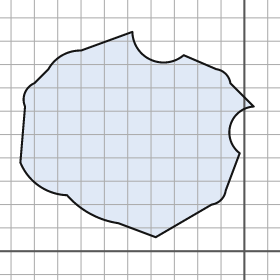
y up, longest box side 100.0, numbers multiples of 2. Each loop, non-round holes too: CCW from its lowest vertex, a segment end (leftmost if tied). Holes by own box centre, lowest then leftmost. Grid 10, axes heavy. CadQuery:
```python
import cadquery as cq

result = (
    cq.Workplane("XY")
    .moveTo(-38.0, 6.0)
    .lineTo(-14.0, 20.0)
    .threePointArc((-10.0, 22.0), (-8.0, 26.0))
    .lineTo(-2.0, 42.0)
    .threePointArc((-6.0, 54.0), (4.0, 62.0))
    .lineTo(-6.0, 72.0)
    .threePointArc((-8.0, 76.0), (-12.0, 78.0))
    .lineTo(-26.0, 84.0)
    .threePointArc((-40.0, 82.0), (-48.0, 94.0))
    .lineTo(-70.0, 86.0)
    .threePointArc((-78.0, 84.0), (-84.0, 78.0))
    .lineTo(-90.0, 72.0)
    .threePointArc((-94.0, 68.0), (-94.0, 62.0))
    .lineTo(-96.0, 38.0)
    .threePointArc((-88.0, 28.0), (-76.0, 24.0))
    .threePointArc((-66.0, 16.0), (-54.0, 12.0))
    .close()
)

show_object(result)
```